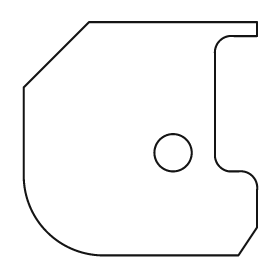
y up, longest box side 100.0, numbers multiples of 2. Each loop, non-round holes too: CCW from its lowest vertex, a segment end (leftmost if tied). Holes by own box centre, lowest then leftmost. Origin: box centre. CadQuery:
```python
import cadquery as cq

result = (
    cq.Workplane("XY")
    .moveTo(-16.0, -50.0)
    .lineTo(42.0, -50.0)
    .lineTo(50.0, -38.0)
    .lineTo(50.0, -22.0)
    .threePointArc((48.0, -16.0), (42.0, -14.0))
    .lineTo(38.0, -14.0)
    .threePointArc((34.0, -12.0), (32.0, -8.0))
    .lineTo(32.0, 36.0)
    .threePointArc((34.0, 42.0), (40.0, 44.0))
    .lineTo(50.0, 44.0)
    .lineTo(50.0, 50.0)
    .lineTo(-22.0, 50.0)
    .lineTo(-50.0, 22.0)
    .lineTo(-50.0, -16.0)
    .threePointArc((-40.0, -40.0), (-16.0, -50.0))
    .close()
    .moveTo(14.0, -6.0)
    .circle(8.0)
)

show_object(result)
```